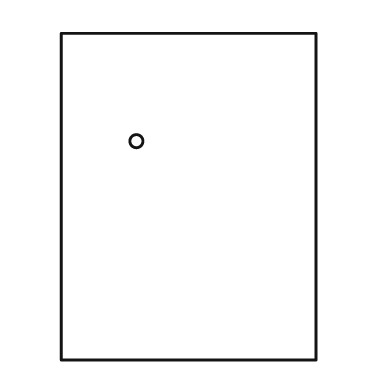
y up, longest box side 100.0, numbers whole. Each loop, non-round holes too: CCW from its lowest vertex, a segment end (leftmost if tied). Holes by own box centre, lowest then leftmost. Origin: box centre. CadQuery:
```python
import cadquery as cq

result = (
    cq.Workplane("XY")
    .moveTo(-39.0, -50.0)
    .lineTo(39.0, -50.0)
    .lineTo(39.0, 50.0)
    .lineTo(-39.0, 50.0)
    .close()
    .moveTo(-16.0, 17.0)
    .circle(2.0)
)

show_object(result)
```